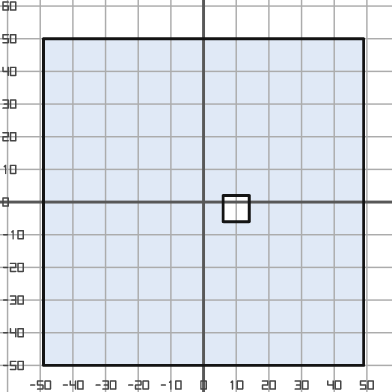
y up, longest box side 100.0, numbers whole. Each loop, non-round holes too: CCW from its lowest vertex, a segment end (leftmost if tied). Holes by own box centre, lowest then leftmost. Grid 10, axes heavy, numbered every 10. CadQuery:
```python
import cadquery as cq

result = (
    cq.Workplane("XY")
    .moveTo(-49.0, -50.0)
    .lineTo(49.0, -50.0)
    .lineTo(49.0, 50.0)
    .lineTo(-49.0, 50.0)
    .close()
    .moveTo(6.0, -6.0)
    .lineTo(14.0, -6.0)
    .lineTo(14.0, 2.0)
    .lineTo(6.0, 2.0)
    .close()
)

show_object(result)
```